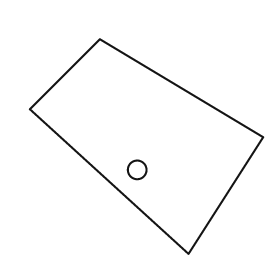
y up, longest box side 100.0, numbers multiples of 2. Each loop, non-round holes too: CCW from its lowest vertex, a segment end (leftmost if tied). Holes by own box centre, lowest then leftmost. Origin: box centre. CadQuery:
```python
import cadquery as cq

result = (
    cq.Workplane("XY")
    .moveTo(18.0, -46.0)
    .lineTo(50.0, 4.0)
    .lineTo(-20.0, 46.0)
    .lineTo(-50.0, 16.0)
    .close()
    .moveTo(-4.0, -10.0)
    .circle(4.0)
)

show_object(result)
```